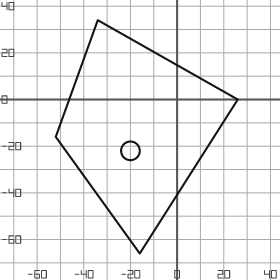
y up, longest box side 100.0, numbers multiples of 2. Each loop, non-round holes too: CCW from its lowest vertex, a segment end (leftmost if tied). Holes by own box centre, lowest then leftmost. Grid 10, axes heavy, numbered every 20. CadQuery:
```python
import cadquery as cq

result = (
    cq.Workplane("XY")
    .moveTo(-16.0, -66.0)
    .lineTo(26.0, 0.0)
    .lineTo(-34.0, 34.0)
    .lineTo(-52.0, -16.0)
    .close()
    .moveTo(-20.0, -22.0)
    .circle(4.0)
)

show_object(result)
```